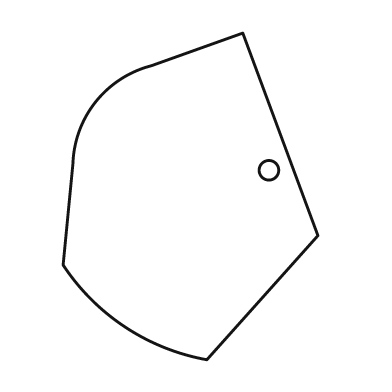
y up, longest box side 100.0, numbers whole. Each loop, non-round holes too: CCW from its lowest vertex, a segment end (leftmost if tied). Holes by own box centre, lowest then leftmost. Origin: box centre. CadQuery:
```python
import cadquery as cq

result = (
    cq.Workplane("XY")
    .moveTo(5.0, -50.0)
    .lineTo(39.0, -12.0)
    .lineTo(16.0, 50.0)
    .lineTo(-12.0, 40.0)
    .threePointArc((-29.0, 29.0), (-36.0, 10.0))
    .lineTo(-39.0, -21.0)
    .threePointArc((-20.0, -40.0), (5.0, -50.0))
    .close()
    .moveTo(24.0, 8.0)
    .circle(3.0)
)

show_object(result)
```